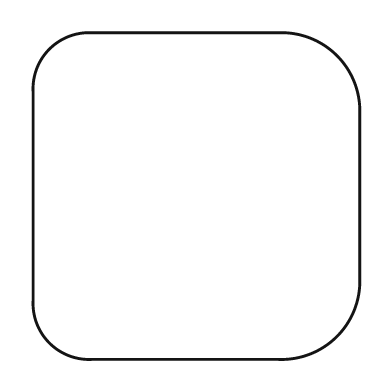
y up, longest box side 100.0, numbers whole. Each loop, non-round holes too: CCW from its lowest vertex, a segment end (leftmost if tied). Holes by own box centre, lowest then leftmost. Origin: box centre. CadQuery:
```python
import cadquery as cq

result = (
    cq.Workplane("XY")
    .moveTo(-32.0, -50.0)
    .lineTo(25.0, -50.0)
    .threePointArc((43.0, -43.0), (50.0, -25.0))
    .lineTo(50.0, 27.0)
    .threePointArc((43.0, 43.0), (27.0, 50.0))
    .lineTo(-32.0, 50.0)
    .threePointArc((-45.0, 45.0), (-50.0, 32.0))
    .lineTo(-50.0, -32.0)
    .threePointArc((-45.0, -45.0), (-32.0, -50.0))
    .close()
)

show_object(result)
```